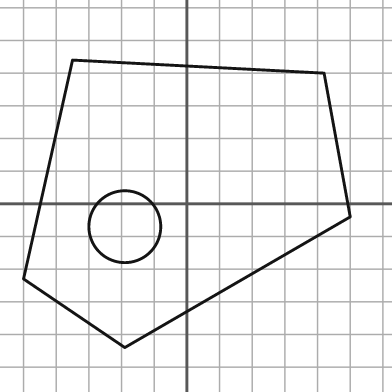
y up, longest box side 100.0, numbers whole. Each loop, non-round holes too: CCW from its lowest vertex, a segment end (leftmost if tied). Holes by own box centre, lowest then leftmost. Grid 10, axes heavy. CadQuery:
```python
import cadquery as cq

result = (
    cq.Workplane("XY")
    .moveTo(-19.0, -44.0)
    .lineTo(50.0, -4.0)
    .lineTo(42.0, 40.0)
    .lineTo(-35.0, 44.0)
    .lineTo(-50.0, -23.0)
    .close()
    .moveTo(-19.0, -7.0)
    .circle(11.0)
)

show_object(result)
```